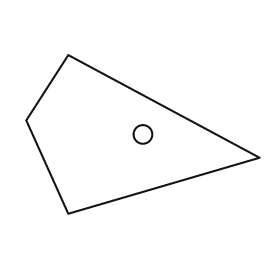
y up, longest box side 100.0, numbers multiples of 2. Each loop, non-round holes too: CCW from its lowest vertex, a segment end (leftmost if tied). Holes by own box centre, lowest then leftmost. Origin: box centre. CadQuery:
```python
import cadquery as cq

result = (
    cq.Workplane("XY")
    .moveTo(-32.0, -34.0)
    .lineTo(50.0, -10.0)
    .lineTo(-32.0, 34.0)
    .lineTo(-50.0, 6.0)
    .close()
    .moveTo(0.0, 0.0)
    .circle(4.0)
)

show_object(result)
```